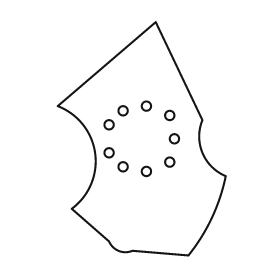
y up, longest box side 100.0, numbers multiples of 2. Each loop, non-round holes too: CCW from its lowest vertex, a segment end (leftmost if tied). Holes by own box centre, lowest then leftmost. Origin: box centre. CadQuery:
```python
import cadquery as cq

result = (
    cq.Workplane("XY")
    .moveTo(20.0, -50.0)
    .threePointArc((30.0, -34.0), (36.0, -16.0))
    .threePointArc((26.0, -6.0), (26.0, 8.0))
    .lineTo(6.0, 50.0)
    .lineTo(-36.0, 14.0)
    .threePointArc((-20.0, -6.0), (-30.0, -30.0))
    .lineTo(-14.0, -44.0)
    .threePointArc((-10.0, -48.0), (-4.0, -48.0))
    .close()
    .moveTo(2.0, -14.0)
    .circle(2.0)
    .moveTo(-8.0, -12.0)
    .circle(2.0)
    .moveTo(12.0, -10.0)
    .circle(2.0)
    .moveTo(-14.0, -6.0)
    .circle(2.0)
    .moveTo(14.0, 0.0)
    .circle(2.0)
    .moveTo(-14.0, 6.0)
    .circle(2.0)
    .moveTo(12.0, 10.0)
    .circle(2.0)
    .moveTo(-8.0, 12.0)
    .circle(2.0)
    .moveTo(2.0, 14.0)
    .circle(2.0)
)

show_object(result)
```